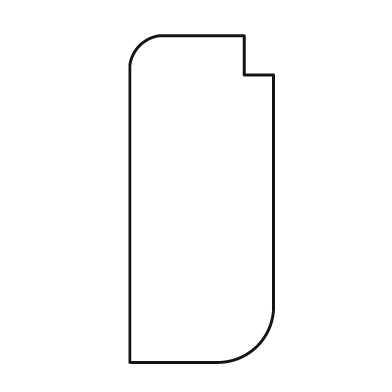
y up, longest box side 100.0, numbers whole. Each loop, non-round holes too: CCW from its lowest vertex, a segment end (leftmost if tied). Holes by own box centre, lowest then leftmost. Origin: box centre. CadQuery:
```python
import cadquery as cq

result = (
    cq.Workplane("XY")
    .moveTo(-22.0, -50.0)
    .lineTo(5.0, -50.0)
    .threePointArc((17.0, -45.0), (22.0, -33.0))
    .lineTo(22.0, 38.0)
    .lineTo(13.0, 38.0)
    .lineTo(13.0, 50.0)
    .lineTo(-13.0, 50.0)
    .threePointArc((-19.0, 47.0), (-22.0, 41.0))
    .close()
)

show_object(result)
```